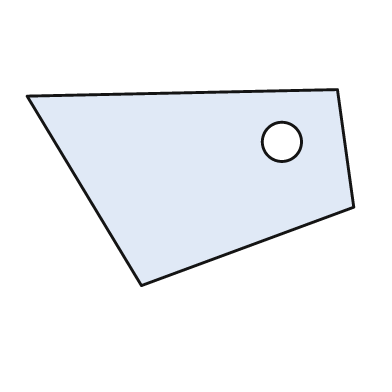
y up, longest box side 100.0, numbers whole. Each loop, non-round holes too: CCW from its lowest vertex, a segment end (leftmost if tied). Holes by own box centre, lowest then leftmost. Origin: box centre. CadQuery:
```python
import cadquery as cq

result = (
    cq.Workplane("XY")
    .moveTo(-15.0, -30.0)
    .lineTo(50.0, -6.0)
    .lineTo(45.0, 30.0)
    .lineTo(-50.0, 28.0)
    .close()
    .moveTo(28.0, 14.0)
    .circle(6.0)
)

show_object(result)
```